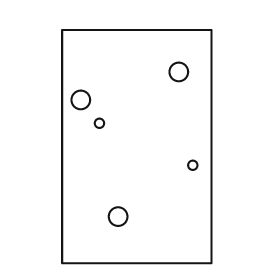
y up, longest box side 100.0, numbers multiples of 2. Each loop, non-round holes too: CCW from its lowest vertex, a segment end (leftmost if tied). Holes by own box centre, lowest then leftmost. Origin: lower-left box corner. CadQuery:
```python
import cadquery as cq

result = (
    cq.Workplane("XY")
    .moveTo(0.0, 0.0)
    .lineTo(64.0, 0.0)
    .lineTo(64.0, 100.0)
    .lineTo(0.0, 100.0)
    .close()
    .moveTo(24.0, 20.0)
    .circle(4.0)
    .moveTo(56.0, 42.0)
    .circle(2.0)
    .moveTo(16.0, 60.0)
    .circle(2.0)
    .moveTo(8.0, 70.0)
    .circle(4.0)
    .moveTo(50.0, 82.0)
    .circle(4.0)
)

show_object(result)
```